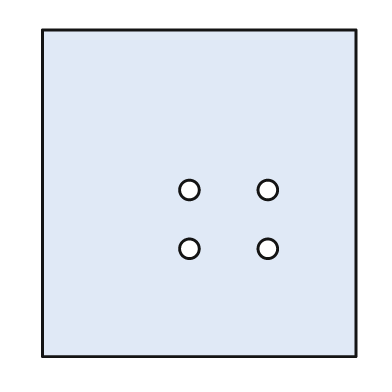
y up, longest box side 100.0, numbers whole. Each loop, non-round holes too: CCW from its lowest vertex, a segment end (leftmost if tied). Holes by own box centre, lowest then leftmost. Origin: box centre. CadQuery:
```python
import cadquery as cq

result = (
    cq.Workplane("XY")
    .moveTo(-48.0, -50.0)
    .lineTo(48.0, -50.0)
    .lineTo(48.0, 50.0)
    .lineTo(-48.0, 50.0)
    .close()
    .moveTo(-3.0, -17.0)
    .circle(3.0)
    .moveTo(21.0, -17.0)
    .circle(3.0)
    .moveTo(-3.0, 1.0)
    .circle(3.0)
    .moveTo(21.0, 1.0)
    .circle(3.0)
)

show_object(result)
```